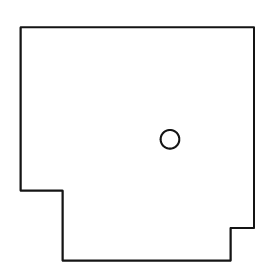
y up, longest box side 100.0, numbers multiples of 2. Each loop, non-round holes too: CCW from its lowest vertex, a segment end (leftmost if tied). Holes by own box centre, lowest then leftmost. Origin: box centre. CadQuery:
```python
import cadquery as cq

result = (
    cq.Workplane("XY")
    .moveTo(-32.0, -50.0)
    .lineTo(40.0, -50.0)
    .lineTo(40.0, -36.0)
    .lineTo(50.0, -36.0)
    .lineTo(50.0, 50.0)
    .lineTo(-50.0, 50.0)
    .lineTo(-50.0, -20.0)
    .lineTo(-32.0, -20.0)
    .close()
    .moveTo(14.0, 2.0)
    .circle(4.0)
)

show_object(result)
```